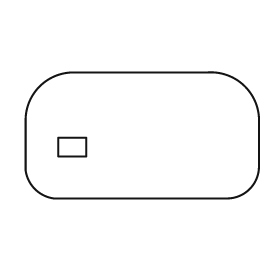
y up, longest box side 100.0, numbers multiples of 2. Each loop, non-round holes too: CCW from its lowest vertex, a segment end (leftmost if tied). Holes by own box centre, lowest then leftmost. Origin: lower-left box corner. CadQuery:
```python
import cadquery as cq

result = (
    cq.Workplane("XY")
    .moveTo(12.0, 0.0)
    .lineTo(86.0, 0.0)
    .threePointArc((96.0, 4.0), (100.0, 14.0))
    .lineTo(100.0, 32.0)
    .threePointArc((94.0, 48.0), (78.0, 54.0))
    .lineTo(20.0, 54.0)
    .threePointArc((6.0, 48.0), (0.0, 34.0))
    .lineTo(0.0, 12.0)
    .threePointArc((4.0, 4.0), (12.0, 0.0))
    .close()
    .moveTo(14.0, 18.0)
    .lineTo(26.0, 18.0)
    .lineTo(26.0, 26.0)
    .lineTo(14.0, 26.0)
    .close()
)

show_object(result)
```